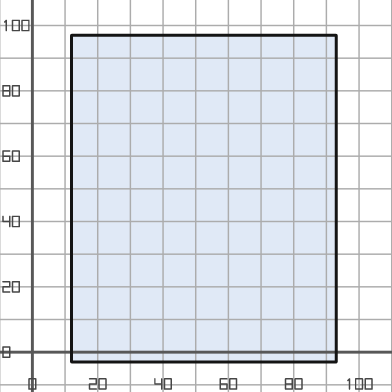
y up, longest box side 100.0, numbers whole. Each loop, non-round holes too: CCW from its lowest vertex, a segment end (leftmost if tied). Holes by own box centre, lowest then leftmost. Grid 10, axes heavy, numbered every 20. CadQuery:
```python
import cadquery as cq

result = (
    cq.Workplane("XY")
    .moveTo(12.0, -3.0)
    .lineTo(93.0, -3.0)
    .lineTo(93.0, 97.0)
    .lineTo(12.0, 97.0)
    .close()
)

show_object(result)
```